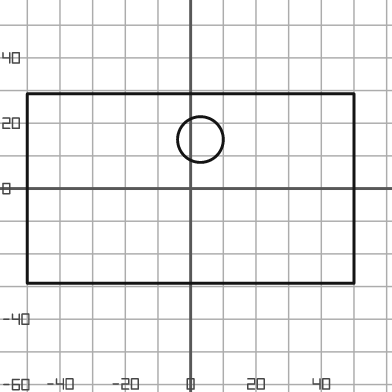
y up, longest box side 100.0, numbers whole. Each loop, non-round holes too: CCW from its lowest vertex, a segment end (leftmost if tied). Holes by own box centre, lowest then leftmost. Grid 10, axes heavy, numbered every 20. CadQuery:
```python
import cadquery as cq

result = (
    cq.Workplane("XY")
    .moveTo(-50.0, -29.0)
    .lineTo(50.0, -29.0)
    .lineTo(50.0, 29.0)
    .lineTo(-50.0, 29.0)
    .close()
    .moveTo(3.0, 15.0)
    .circle(7.0)
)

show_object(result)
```